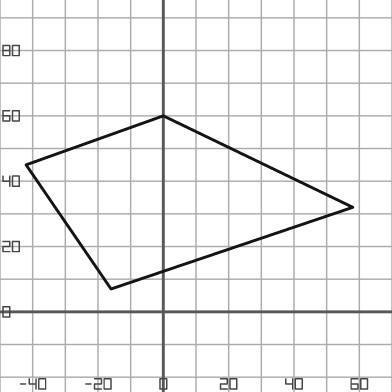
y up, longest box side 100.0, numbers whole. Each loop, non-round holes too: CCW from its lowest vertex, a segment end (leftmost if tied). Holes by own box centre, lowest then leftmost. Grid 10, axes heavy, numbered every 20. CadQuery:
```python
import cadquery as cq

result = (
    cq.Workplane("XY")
    .moveTo(-16.0, 7.0)
    .lineTo(58.0, 32.0)
    .lineTo(0.0, 60.0)
    .lineTo(-42.0, 45.0)
    .close()
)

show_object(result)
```